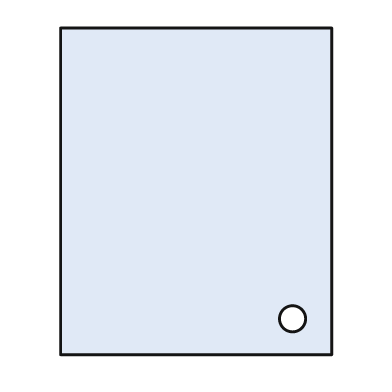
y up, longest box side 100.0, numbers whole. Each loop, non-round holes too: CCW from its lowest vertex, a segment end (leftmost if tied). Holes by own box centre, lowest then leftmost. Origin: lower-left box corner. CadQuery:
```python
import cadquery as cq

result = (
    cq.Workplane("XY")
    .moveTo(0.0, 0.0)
    .lineTo(83.0, 0.0)
    .lineTo(83.0, 100.0)
    .lineTo(0.0, 100.0)
    .close()
    .moveTo(71.0, 11.0)
    .circle(4.0)
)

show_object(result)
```